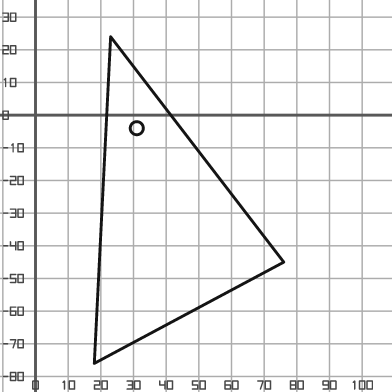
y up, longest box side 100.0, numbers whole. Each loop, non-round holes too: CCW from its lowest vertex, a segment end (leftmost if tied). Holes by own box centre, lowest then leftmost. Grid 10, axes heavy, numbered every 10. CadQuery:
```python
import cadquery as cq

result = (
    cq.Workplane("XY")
    .moveTo(18.0, -76.0)
    .lineTo(76.0, -45.0)
    .lineTo(23.0, 24.0)
    .close()
    .moveTo(31.0, -4.0)
    .circle(2.0)
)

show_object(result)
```